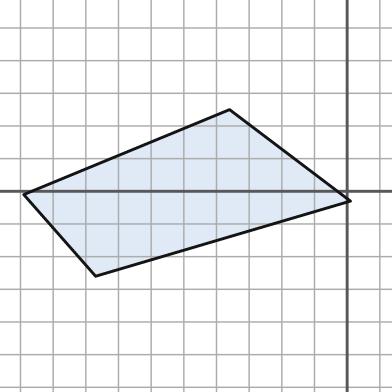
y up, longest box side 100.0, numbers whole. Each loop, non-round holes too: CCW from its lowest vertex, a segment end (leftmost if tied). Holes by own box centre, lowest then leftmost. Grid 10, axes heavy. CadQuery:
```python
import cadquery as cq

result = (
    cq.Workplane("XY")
    .moveTo(-77.0, -26.0)
    .lineTo(1.0, -3.0)
    .lineTo(-36.0, 25.0)
    .lineTo(-99.0, -1.0)
    .close()
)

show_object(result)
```